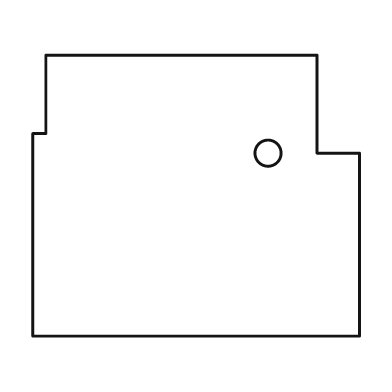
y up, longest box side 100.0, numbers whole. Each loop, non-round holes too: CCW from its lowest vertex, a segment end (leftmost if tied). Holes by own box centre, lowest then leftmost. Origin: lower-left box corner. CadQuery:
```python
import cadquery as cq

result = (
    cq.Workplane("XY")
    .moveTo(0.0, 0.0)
    .lineTo(100.0, 0.0)
    .lineTo(100.0, 56.0)
    .lineTo(87.0, 56.0)
    .lineTo(87.0, 86.0)
    .lineTo(4.0, 86.0)
    .lineTo(4.0, 62.0)
    .lineTo(0.0, 62.0)
    .close()
    .moveTo(72.0, 56.0)
    .circle(4.0)
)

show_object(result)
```